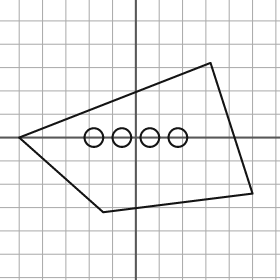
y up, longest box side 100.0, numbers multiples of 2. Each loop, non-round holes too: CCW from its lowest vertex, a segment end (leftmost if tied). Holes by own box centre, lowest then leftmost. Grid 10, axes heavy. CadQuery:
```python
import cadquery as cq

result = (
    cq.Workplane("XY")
    .moveTo(-14.0, -32.0)
    .lineTo(50.0, -24.0)
    .lineTo(32.0, 32.0)
    .lineTo(-50.0, 0.0)
    .close()
    .moveTo(-18.0, 0.0)
    .circle(4.0)
    .moveTo(-6.0, 0.0)
    .circle(4.0)
    .moveTo(6.0, 0.0)
    .circle(4.0)
    .moveTo(18.0, 0.0)
    .circle(4.0)
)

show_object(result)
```